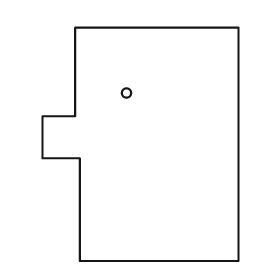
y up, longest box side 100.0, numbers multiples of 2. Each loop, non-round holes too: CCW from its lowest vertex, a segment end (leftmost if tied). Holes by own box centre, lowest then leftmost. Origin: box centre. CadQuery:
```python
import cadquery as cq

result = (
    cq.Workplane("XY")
    .moveTo(-26.0, -50.0)
    .lineTo(42.0, -50.0)
    .lineTo(42.0, 50.0)
    .lineTo(-28.0, 50.0)
    .lineTo(-28.0, 12.0)
    .lineTo(-42.0, 12.0)
    .lineTo(-42.0, -6.0)
    .lineTo(-26.0, -6.0)
    .close()
    .moveTo(-6.0, 22.0)
    .circle(2.0)
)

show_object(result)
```